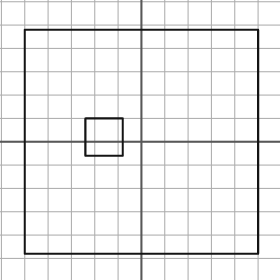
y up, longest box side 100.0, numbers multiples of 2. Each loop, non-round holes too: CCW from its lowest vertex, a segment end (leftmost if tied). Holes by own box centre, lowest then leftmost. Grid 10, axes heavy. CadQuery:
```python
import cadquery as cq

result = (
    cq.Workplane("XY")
    .moveTo(-50.0, -48.0)
    .lineTo(50.0, -48.0)
    .lineTo(50.0, 48.0)
    .lineTo(-50.0, 48.0)
    .close()
    .moveTo(-24.0, -6.0)
    .lineTo(-8.0, -6.0)
    .lineTo(-8.0, 10.0)
    .lineTo(-24.0, 10.0)
    .close()
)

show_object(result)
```